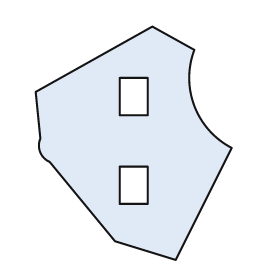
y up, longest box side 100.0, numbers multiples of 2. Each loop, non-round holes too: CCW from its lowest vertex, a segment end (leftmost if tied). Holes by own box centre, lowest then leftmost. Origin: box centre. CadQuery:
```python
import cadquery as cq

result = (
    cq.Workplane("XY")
    .moveTo(18.0, -50.0)
    .lineTo(42.0, -2.0)
    .threePointArc((26.0, 16.0), (26.0, 40.0))
    .lineTo(8.0, 50.0)
    .lineTo(-42.0, 22.0)
    .lineTo(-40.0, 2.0)
    .threePointArc((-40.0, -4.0), (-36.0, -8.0))
    .lineTo(-8.0, -42.0)
    .close()
    .moveTo(-6.0, -26.0)
    .lineTo(6.0, -26.0)
    .lineTo(6.0, -10.0)
    .lineTo(-6.0, -10.0)
    .close()
    .moveTo(-6.0, 12.0)
    .lineTo(6.0, 12.0)
    .lineTo(6.0, 28.0)
    .lineTo(-6.0, 28.0)
    .close()
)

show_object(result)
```